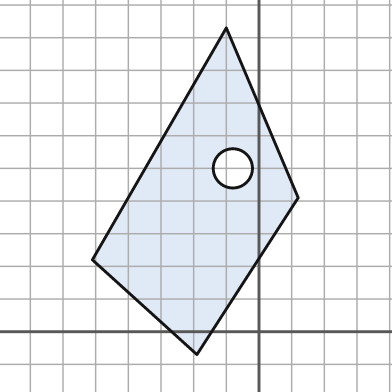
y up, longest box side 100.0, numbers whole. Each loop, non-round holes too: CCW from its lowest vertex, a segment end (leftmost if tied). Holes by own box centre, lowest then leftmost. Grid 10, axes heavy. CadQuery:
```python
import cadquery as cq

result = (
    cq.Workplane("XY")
    .moveTo(-19.0, -7.0)
    .lineTo(12.0, 41.0)
    .lineTo(-10.0, 93.0)
    .lineTo(-51.0, 22.0)
    .close()
    .moveTo(-8.0, 50.0)
    .circle(6.0)
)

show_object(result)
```